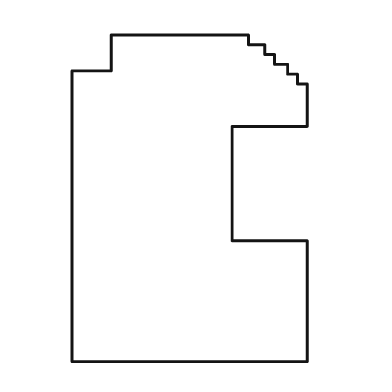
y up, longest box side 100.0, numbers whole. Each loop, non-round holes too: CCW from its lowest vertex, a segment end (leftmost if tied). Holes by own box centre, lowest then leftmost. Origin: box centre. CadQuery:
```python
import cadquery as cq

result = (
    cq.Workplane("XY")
    .moveTo(-36.0, -50.0)
    .lineTo(36.0, -50.0)
    .lineTo(36.0, -13.0)
    .lineTo(13.0, -13.0)
    .lineTo(13.0, 22.0)
    .lineTo(36.0, 22.0)
    .lineTo(36.0, 35.0)
    .lineTo(33.0, 35.0)
    .lineTo(33.0, 38.0)
    .lineTo(30.0, 38.0)
    .lineTo(30.0, 41.0)
    .lineTo(26.0, 41.0)
    .lineTo(26.0, 44.0)
    .lineTo(23.0, 44.0)
    .lineTo(23.0, 47.0)
    .lineTo(18.0, 47.0)
    .lineTo(18.0, 50.0)
    .lineTo(-24.0, 50.0)
    .lineTo(-24.0, 39.0)
    .lineTo(-36.0, 39.0)
    .close()
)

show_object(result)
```